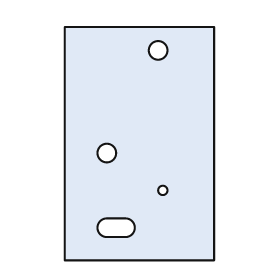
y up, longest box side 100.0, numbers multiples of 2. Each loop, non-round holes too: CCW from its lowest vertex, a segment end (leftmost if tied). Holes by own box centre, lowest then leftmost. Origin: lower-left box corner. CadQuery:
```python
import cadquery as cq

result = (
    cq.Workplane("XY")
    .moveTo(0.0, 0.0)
    .lineTo(64.0, 0.0)
    .lineTo(64.0, 100.0)
    .lineTo(0.0, 100.0)
    .close()
    .moveTo(18.0, 10.0)
    .lineTo(26.0, 10.0)
    .threePointArc((30.0, 14.0), (26.0, 18.0))
    .lineTo(18.0, 18.0)
    .threePointArc((14.0, 14.0), (18.0, 10.0))
    .close()
    .moveTo(42.0, 30.0)
    .circle(2.0)
    .moveTo(18.0, 46.0)
    .circle(4.0)
    .moveTo(40.0, 90.0)
    .circle(4.0)
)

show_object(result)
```